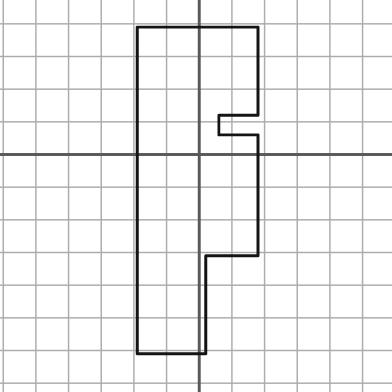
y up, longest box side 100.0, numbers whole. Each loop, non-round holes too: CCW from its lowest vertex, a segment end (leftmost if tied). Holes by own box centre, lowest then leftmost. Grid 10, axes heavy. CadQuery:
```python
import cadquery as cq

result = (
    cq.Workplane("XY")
    .moveTo(-19.0, -61.0)
    .lineTo(2.0, -61.0)
    .lineTo(2.0, -31.0)
    .lineTo(18.0, -31.0)
    .lineTo(18.0, 6.0)
    .lineTo(6.0, 6.0)
    .lineTo(6.0, 12.0)
    .lineTo(18.0, 12.0)
    .lineTo(18.0, 39.0)
    .lineTo(-19.0, 39.0)
    .close()
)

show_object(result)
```